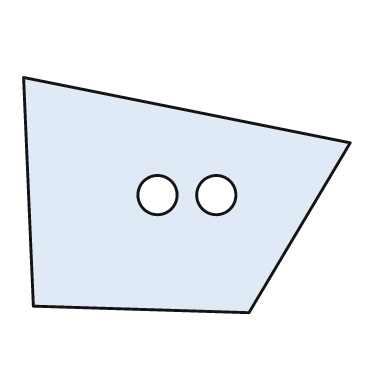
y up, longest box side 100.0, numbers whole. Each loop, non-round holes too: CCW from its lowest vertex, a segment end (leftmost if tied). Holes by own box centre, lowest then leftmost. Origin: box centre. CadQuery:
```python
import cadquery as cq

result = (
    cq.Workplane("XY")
    .moveTo(19.0, -36.0)
    .lineTo(50.0, 16.0)
    .lineTo(-50.0, 36.0)
    .lineTo(-47.0, -34.0)
    .close()
    .moveTo(-9.0, 0.0)
    .circle(6.0)
    .moveTo(9.0, 0.0)
    .circle(6.0)
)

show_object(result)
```